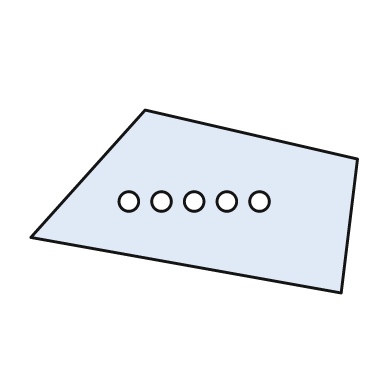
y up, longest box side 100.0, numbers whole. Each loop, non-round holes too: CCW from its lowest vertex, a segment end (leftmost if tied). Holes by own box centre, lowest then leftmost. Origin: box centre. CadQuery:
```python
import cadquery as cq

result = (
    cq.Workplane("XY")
    .moveTo(45.0, -28.0)
    .lineTo(50.0, 13.0)
    .lineTo(-15.0, 28.0)
    .lineTo(-50.0, -11.0)
    .close()
    .moveTo(-20.0, 0.0)
    .circle(3.0)
    .moveTo(-10.0, 0.0)
    .circle(3.0)
    .moveTo(0.0, 0.0)
    .circle(3.0)
    .moveTo(10.0, 0.0)
    .circle(3.0)
    .moveTo(20.0, 0.0)
    .circle(3.0)
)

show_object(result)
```